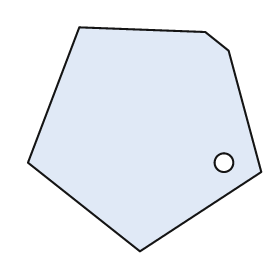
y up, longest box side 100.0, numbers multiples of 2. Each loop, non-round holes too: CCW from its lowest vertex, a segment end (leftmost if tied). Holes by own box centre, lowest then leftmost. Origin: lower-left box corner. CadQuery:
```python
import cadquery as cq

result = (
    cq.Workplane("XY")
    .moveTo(48.0, 0.0)
    .lineTo(100.0, 34.0)
    .lineTo(86.0, 86.0)
    .lineTo(76.0, 94.0)
    .lineTo(22.0, 96.0)
    .lineTo(0.0, 38.0)
    .close()
    .moveTo(84.0, 38.0)
    .circle(4.0)
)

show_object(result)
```